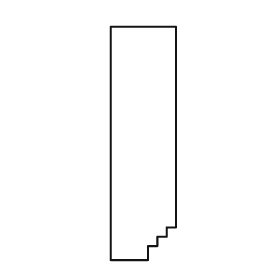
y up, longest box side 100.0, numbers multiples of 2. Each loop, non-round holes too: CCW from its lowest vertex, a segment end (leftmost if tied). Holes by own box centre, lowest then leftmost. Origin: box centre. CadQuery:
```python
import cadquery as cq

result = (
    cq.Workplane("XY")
    .moveTo(-14.0, -50.0)
    .lineTo(2.0, -50.0)
    .lineTo(2.0, -44.0)
    .lineTo(6.0, -44.0)
    .lineTo(6.0, -40.0)
    .lineTo(10.0, -40.0)
    .lineTo(10.0, -36.0)
    .lineTo(14.0, -36.0)
    .lineTo(14.0, 50.0)
    .lineTo(-14.0, 50.0)
    .close()
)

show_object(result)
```